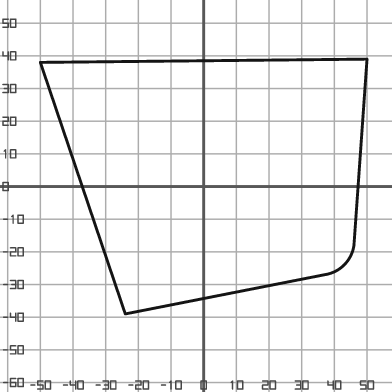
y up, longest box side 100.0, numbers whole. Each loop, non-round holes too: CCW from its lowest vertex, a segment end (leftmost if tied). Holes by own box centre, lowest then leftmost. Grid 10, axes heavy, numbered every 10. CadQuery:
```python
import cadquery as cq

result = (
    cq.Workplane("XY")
    .moveTo(-24.0, -39.0)
    .lineTo(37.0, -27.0)
    .threePointArc((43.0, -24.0), (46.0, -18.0))
    .lineTo(50.0, 39.0)
    .lineTo(-50.0, 38.0)
    .close()
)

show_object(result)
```